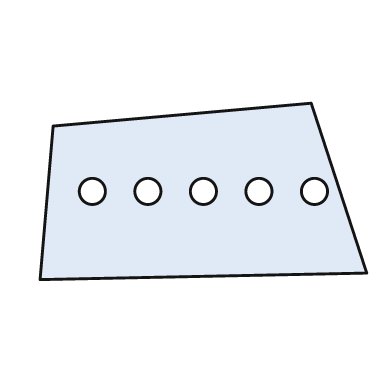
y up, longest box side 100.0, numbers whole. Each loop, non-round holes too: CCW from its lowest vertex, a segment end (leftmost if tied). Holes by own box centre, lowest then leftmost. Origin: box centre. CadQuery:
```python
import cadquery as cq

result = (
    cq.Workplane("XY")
    .moveTo(-50.0, -27.0)
    .lineTo(50.0, -25.0)
    .lineTo(33.0, 27.0)
    .lineTo(-46.0, 20.0)
    .close()
    .moveTo(-34.0, 0.0)
    .circle(4.0)
    .moveTo(-17.0, 0.0)
    .circle(4.0)
    .moveTo(0.0, 0.0)
    .circle(4.0)
    .moveTo(17.0, 0.0)
    .circle(4.0)
    .moveTo(34.0, 0.0)
    .circle(4.0)
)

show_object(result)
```